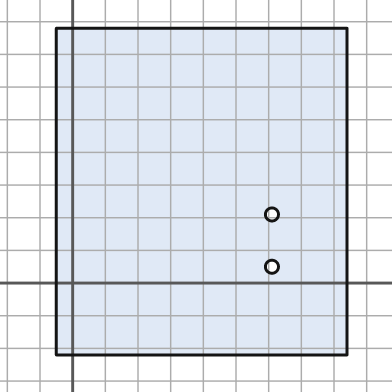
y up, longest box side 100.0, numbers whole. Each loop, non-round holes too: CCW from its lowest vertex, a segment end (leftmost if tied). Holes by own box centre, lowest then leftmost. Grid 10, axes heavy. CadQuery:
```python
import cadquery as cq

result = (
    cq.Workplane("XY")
    .moveTo(-5.0, -22.0)
    .lineTo(84.0, -22.0)
    .lineTo(84.0, 78.0)
    .lineTo(-5.0, 78.0)
    .close()
    .moveTo(61.0, 5.0)
    .circle(2.0)
    .moveTo(61.0, 21.0)
    .circle(2.0)
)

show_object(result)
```